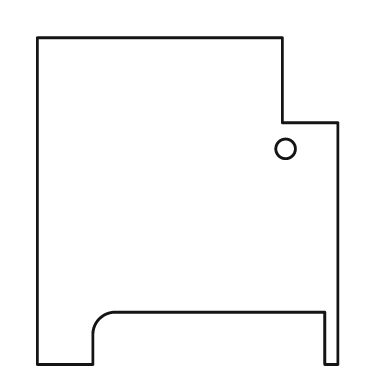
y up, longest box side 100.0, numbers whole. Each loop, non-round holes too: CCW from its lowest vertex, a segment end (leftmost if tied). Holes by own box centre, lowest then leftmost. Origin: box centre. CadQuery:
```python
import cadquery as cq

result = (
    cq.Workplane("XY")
    .moveTo(-46.0, -50.0)
    .lineTo(-29.0, -50.0)
    .lineTo(-29.0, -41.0)
    .threePointArc((-27.0, -36.0), (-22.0, -34.0))
    .lineTo(42.0, -34.0)
    .lineTo(42.0, -50.0)
    .lineTo(46.0, -50.0)
    .lineTo(46.0, 24.0)
    .lineTo(29.0, 24.0)
    .lineTo(29.0, 50.0)
    .lineTo(-46.0, 50.0)
    .close()
    .moveTo(30.0, 16.0)
    .circle(3.0)
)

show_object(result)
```